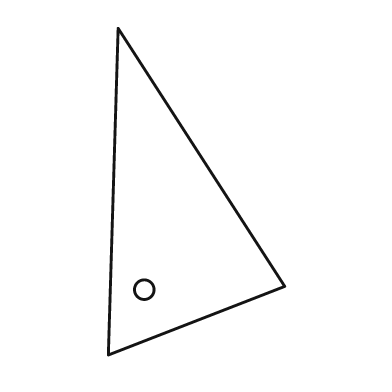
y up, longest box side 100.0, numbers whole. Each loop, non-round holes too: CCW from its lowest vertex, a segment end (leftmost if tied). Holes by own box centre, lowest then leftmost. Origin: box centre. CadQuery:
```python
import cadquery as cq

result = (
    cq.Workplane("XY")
    .moveTo(-27.0, -50.0)
    .lineTo(27.0, -29.0)
    .lineTo(-24.0, 50.0)
    .close()
    .moveTo(-16.0, -30.0)
    .circle(3.0)
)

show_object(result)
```